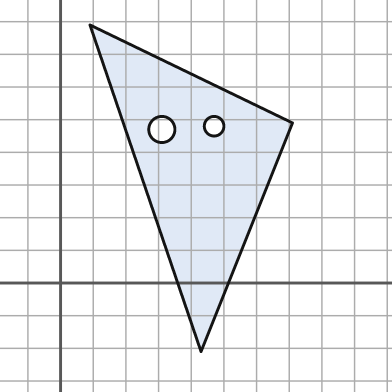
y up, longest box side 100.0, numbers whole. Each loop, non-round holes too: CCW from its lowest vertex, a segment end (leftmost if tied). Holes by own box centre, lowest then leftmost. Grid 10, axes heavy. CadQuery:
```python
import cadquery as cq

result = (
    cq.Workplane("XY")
    .moveTo(43.0, -21.0)
    .lineTo(71.0, 49.0)
    .lineTo(9.0, 79.0)
    .close()
    .moveTo(31.0, 47.0)
    .circle(4.0)
    .moveTo(47.0, 48.0)
    .circle(3.0)
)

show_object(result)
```